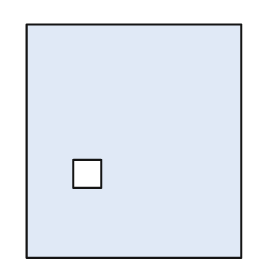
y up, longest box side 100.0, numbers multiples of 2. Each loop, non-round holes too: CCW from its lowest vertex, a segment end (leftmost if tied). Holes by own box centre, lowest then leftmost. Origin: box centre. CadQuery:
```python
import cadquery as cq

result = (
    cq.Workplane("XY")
    .moveTo(-46.0, -50.0)
    .lineTo(46.0, -50.0)
    .lineTo(46.0, 50.0)
    .lineTo(-46.0, 50.0)
    .close()
    .moveTo(-26.0, -20.0)
    .lineTo(-14.0, -20.0)
    .lineTo(-14.0, -8.0)
    .lineTo(-26.0, -8.0)
    .close()
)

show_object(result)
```